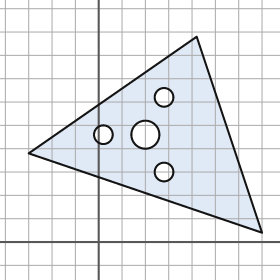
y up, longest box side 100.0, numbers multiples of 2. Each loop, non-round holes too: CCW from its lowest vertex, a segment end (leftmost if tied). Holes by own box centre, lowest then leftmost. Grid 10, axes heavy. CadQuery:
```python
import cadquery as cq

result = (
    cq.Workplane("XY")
    .moveTo(70.0, 4.0)
    .lineTo(42.0, 88.0)
    .lineTo(-30.0, 38.0)
    .close()
    .moveTo(28.0, 30.0)
    .circle(4.0)
    .moveTo(2.0, 46.0)
    .circle(4.0)
    .moveTo(20.0, 46.0)
    .circle(6.0)
    .moveTo(28.0, 62.0)
    .circle(4.0)
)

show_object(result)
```